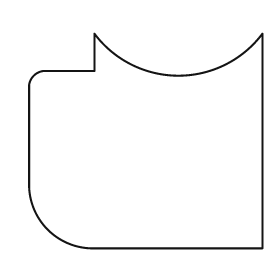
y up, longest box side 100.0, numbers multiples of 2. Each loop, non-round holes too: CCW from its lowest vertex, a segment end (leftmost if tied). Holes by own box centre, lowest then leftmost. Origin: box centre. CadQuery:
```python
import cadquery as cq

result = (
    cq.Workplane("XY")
    .moveTo(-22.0, -46.0)
    .lineTo(50.0, -46.0)
    .lineTo(50.0, 46.0)
    .threePointArc((14.0, 28.0), (-22.0, 46.0))
    .lineTo(-22.0, 30.0)
    .lineTo(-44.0, 30.0)
    .threePointArc((-48.0, 28.0), (-50.0, 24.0))
    .lineTo(-50.0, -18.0)
    .threePointArc((-42.0, -38.0), (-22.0, -46.0))
    .close()
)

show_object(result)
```